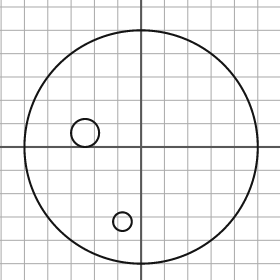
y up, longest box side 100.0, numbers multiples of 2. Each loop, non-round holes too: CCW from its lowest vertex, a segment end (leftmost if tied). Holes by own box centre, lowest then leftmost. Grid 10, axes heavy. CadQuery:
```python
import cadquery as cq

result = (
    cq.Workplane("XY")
    .moveTo(0.0, 0.0)
    .circle(50.0)
    .moveTo(-8.0, -32.0)
    .circle(4.0)
    .moveTo(-24.0, 6.0)
    .circle(6.0)
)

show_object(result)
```